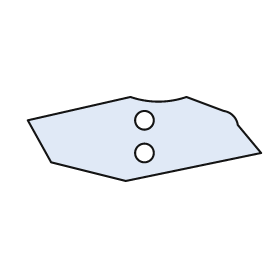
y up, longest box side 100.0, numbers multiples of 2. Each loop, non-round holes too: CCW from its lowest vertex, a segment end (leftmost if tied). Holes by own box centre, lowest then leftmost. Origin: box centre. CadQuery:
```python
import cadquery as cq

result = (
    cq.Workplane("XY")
    .moveTo(-8.0, -18.0)
    .lineTo(50.0, -6.0)
    .lineTo(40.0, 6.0)
    .threePointArc((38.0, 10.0), (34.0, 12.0))
    .lineTo(18.0, 18.0)
    .threePointArc((6.0, 16.0), (-6.0, 18.0))
    .lineTo(-50.0, 8.0)
    .lineTo(-40.0, -10.0)
    .close()
    .moveTo(0.0, -6.0)
    .circle(4.0)
    .moveTo(0.0, 8.0)
    .circle(4.0)
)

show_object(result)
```